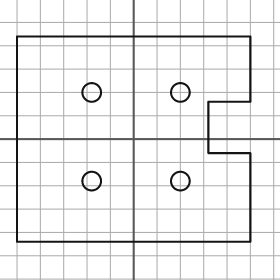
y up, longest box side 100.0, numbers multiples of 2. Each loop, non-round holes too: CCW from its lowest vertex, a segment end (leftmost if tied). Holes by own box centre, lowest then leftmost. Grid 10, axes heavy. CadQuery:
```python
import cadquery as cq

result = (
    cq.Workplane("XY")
    .moveTo(-50.0, -44.0)
    .lineTo(50.0, -44.0)
    .lineTo(50.0, -6.0)
    .lineTo(32.0, -6.0)
    .lineTo(32.0, 16.0)
    .lineTo(50.0, 16.0)
    .lineTo(50.0, 44.0)
    .lineTo(-50.0, 44.0)
    .close()
    .moveTo(-18.0, -18.0)
    .circle(4.0)
    .moveTo(20.0, -18.0)
    .circle(4.0)
    .moveTo(-18.0, 20.0)
    .circle(4.0)
    .moveTo(20.0, 20.0)
    .circle(4.0)
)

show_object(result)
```